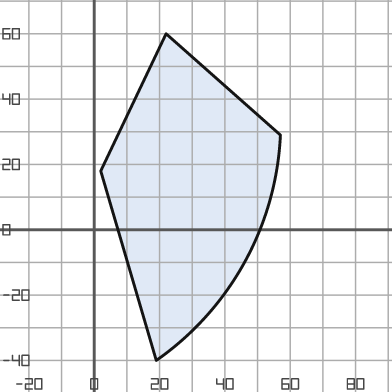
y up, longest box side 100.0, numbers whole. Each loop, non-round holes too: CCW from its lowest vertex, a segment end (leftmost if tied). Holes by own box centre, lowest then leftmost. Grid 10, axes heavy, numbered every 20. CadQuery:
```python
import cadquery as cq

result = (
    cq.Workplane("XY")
    .moveTo(19.0, -40.0)
    .threePointArc((46.0, -10.0), (57.0, 29.0))
    .lineTo(22.0, 60.0)
    .lineTo(2.0, 18.0)
    .close()
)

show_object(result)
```